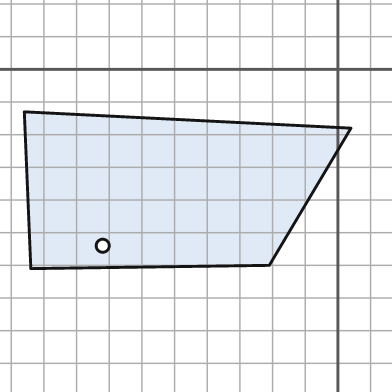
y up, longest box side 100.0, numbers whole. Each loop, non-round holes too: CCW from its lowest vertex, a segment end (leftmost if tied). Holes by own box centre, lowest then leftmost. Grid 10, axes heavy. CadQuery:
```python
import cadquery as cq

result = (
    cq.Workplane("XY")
    .moveTo(-94.0, -61.0)
    .lineTo(-21.0, -60.0)
    .lineTo(4.0, -18.0)
    .lineTo(-96.0, -13.0)
    .close()
    .moveTo(-72.0, -54.0)
    .circle(2.0)
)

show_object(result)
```